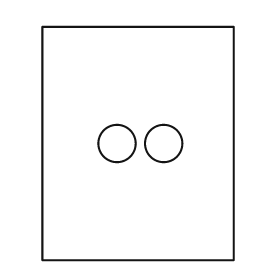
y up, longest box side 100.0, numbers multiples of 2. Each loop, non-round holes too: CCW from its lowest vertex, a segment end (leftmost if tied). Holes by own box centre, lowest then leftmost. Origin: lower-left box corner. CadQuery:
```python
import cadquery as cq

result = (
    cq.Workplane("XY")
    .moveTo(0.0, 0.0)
    .lineTo(82.0, 0.0)
    .lineTo(82.0, 100.0)
    .lineTo(0.0, 100.0)
    .close()
    .moveTo(32.0, 50.0)
    .circle(8.0)
    .moveTo(52.0, 50.0)
    .circle(8.0)
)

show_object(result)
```